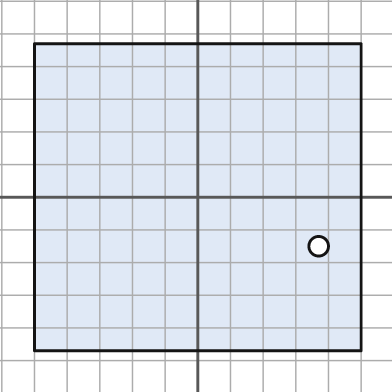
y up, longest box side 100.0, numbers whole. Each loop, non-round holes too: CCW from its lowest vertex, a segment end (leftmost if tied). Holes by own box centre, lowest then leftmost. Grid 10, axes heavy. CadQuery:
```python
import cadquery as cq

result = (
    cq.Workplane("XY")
    .moveTo(-50.0, -47.0)
    .lineTo(50.0, -47.0)
    .lineTo(50.0, 47.0)
    .lineTo(-50.0, 47.0)
    .close()
    .moveTo(37.0, -15.0)
    .circle(3.0)
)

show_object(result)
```